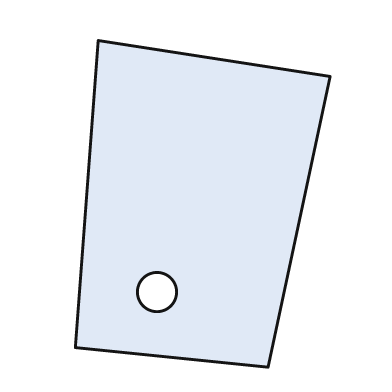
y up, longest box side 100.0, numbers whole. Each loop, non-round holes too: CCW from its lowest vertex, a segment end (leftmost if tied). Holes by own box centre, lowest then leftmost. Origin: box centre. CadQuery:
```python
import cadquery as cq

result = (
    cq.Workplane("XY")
    .moveTo(20.0, -50.0)
    .lineTo(39.0, 39.0)
    .lineTo(-32.0, 50.0)
    .lineTo(-39.0, -44.0)
    .close()
    .moveTo(-14.0, -27.0)
    .circle(6.0)
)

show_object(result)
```